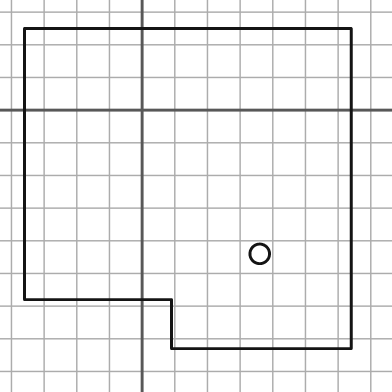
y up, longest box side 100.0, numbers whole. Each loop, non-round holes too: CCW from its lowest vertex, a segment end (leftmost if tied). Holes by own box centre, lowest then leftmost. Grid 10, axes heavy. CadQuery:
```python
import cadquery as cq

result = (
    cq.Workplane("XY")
    .moveTo(9.0, -73.0)
    .lineTo(64.0, -73.0)
    .lineTo(64.0, 25.0)
    .lineTo(-36.0, 25.0)
    .lineTo(-36.0, -58.0)
    .lineTo(9.0, -58.0)
    .close()
    .moveTo(36.0, -44.0)
    .circle(3.0)
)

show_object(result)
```